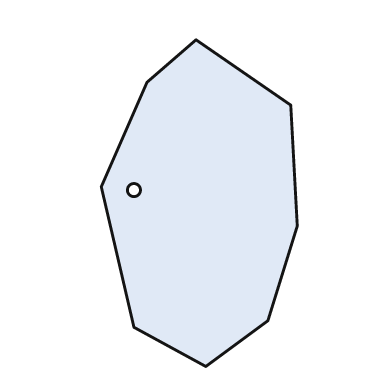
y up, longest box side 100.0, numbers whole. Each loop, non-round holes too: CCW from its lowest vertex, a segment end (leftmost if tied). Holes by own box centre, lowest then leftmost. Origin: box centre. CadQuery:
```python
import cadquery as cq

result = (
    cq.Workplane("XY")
    .moveTo(2.0, -50.0)
    .lineTo(21.0, -36.0)
    .lineTo(30.0, -7.0)
    .lineTo(28.0, 30.0)
    .lineTo(-1.0, 50.0)
    .lineTo(-16.0, 37.0)
    .lineTo(-30.0, 5.0)
    .lineTo(-20.0, -38.0)
    .close()
    .moveTo(-20.0, 4.0)
    .circle(2.0)
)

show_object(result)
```